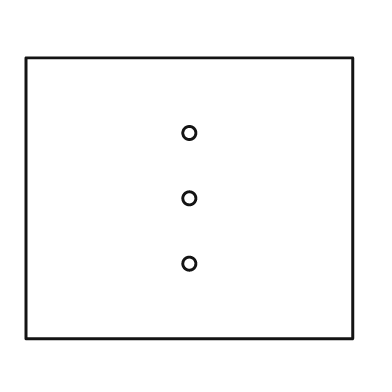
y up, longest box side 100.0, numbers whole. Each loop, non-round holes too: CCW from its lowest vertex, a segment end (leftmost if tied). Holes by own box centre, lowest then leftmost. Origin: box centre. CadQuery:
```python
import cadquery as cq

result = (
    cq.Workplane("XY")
    .moveTo(-50.0, -43.0)
    .lineTo(50.0, -43.0)
    .lineTo(50.0, 43.0)
    .lineTo(-50.0, 43.0)
    .close()
    .moveTo(0.0, -20.0)
    .circle(2.0)
    .moveTo(0.0, 0.0)
    .circle(2.0)
    .moveTo(0.0, 20.0)
    .circle(2.0)
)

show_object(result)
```